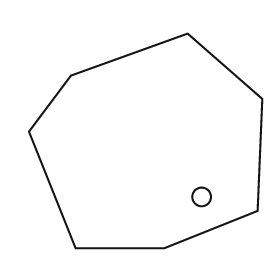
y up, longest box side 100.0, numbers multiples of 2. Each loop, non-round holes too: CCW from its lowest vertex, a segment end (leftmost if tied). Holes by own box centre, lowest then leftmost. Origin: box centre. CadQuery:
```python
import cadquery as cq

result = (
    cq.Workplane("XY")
    .moveTo(-30.0, -46.0)
    .lineTo(8.0, -46.0)
    .lineTo(48.0, -30.0)
    .lineTo(50.0, 18.0)
    .lineTo(18.0, 46.0)
    .lineTo(-32.0, 28.0)
    .lineTo(-50.0, 4.0)
    .close()
    .moveTo(24.0, -24.0)
    .circle(4.0)
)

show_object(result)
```